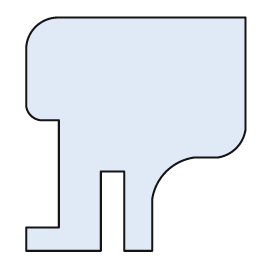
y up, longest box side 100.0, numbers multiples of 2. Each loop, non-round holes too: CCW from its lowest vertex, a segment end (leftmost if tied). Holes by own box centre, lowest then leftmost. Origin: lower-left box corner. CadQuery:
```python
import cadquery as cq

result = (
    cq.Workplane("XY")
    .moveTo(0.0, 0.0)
    .lineTo(32.0, 0.0)
    .lineTo(32.0, 34.0)
    .lineTo(42.0, 34.0)
    .lineTo(42.0, 0.0)
    .lineTo(54.0, 0.0)
    .lineTo(54.0, 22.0)
    .threePointArc((60.0, 34.0), (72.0, 40.0))
    .lineTo(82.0, 40.0)
    .threePointArc((90.0, 44.0), (94.0, 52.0))
    .lineTo(94.0, 100.0)
    .lineTo(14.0, 100.0)
    .threePointArc((4.0, 96.0), (0.0, 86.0))
    .lineTo(0.0, 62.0)
    .threePointArc((2.0, 58.0), (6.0, 56.0))
    .lineTo(14.0, 56.0)
    .lineTo(14.0, 10.0)
    .lineTo(0.0, 10.0)
    .close()
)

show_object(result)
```